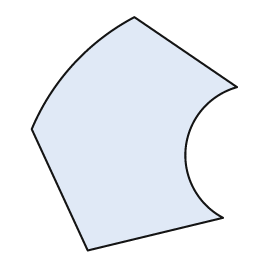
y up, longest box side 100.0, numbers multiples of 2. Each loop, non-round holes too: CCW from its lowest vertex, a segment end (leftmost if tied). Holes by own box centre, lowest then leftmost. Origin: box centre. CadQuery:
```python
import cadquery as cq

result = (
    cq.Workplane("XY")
    .moveTo(-20.0, -50.0)
    .lineTo(38.0, -36.0)
    .threePointArc((22.0, -6.0), (44.0, 20.0))
    .lineTo(0.0, 50.0)
    .threePointArc((-26.0, 30.0), (-44.0, 2.0))
    .close()
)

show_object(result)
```